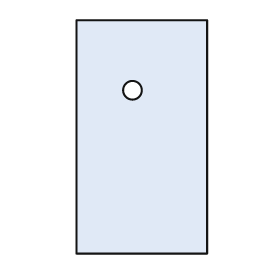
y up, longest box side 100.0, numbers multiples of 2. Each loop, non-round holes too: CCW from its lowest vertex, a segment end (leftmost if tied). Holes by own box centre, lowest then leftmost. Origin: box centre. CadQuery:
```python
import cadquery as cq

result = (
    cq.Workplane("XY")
    .moveTo(-28.0, -50.0)
    .lineTo(28.0, -50.0)
    .lineTo(28.0, 50.0)
    .lineTo(-28.0, 50.0)
    .close()
    .moveTo(-4.0, 20.0)
    .circle(4.0)
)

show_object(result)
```